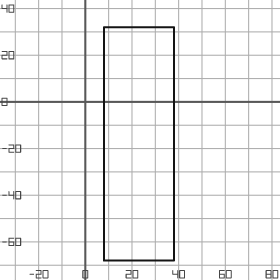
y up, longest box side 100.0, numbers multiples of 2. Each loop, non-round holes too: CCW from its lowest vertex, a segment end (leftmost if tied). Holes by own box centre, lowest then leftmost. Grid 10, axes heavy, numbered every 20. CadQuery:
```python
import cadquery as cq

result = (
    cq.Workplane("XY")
    .moveTo(8.0, -68.0)
    .lineTo(38.0, -68.0)
    .lineTo(38.0, 32.0)
    .lineTo(8.0, 32.0)
    .close()
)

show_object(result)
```